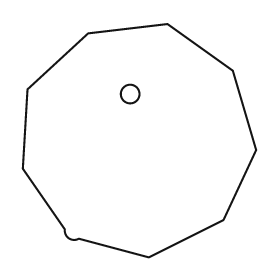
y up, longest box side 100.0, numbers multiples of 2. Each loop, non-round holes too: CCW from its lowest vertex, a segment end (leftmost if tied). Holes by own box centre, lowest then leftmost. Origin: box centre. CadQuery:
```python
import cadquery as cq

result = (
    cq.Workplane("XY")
    .moveTo(4.0, -50.0)
    .lineTo(36.0, -34.0)
    .lineTo(50.0, -4.0)
    .lineTo(40.0, 30.0)
    .lineTo(12.0, 50.0)
    .lineTo(-22.0, 46.0)
    .lineTo(-48.0, 22.0)
    .lineTo(-50.0, -12.0)
    .lineTo(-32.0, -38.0)
    .threePointArc((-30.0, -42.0), (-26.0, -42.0))
    .close()
    .moveTo(-4.0, 20.0)
    .circle(4.0)
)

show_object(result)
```